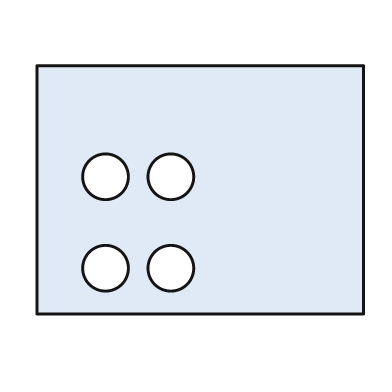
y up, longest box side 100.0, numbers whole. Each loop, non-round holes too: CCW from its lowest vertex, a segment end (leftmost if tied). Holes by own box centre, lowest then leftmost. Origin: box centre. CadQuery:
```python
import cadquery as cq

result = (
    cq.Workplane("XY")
    .moveTo(-50.0, -38.0)
    .lineTo(50.0, -38.0)
    .lineTo(50.0, 38.0)
    .lineTo(-50.0, 38.0)
    .close()
    .moveTo(-29.0, -24.0)
    .circle(7.0)
    .moveTo(-9.0, -24.0)
    .circle(7.0)
    .moveTo(-29.0, 4.0)
    .circle(7.0)
    .moveTo(-9.0, 4.0)
    .circle(7.0)
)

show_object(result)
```